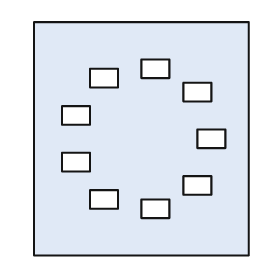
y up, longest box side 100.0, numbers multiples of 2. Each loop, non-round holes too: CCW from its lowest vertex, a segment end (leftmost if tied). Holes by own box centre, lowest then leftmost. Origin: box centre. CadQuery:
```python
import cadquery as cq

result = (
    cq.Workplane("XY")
    .moveTo(-46.0, -50.0)
    .lineTo(46.0, -50.0)
    .lineTo(46.0, 50.0)
    .lineTo(-46.0, 50.0)
    .close()
    .moveTo(0.0, -34.0)
    .lineTo(12.0, -34.0)
    .lineTo(12.0, -26.0)
    .lineTo(0.0, -26.0)
    .close()
    .moveTo(-22.0, -30.0)
    .lineTo(-10.0, -30.0)
    .lineTo(-10.0, -22.0)
    .lineTo(-22.0, -22.0)
    .close()
    .moveTo(18.0, -24.0)
    .lineTo(30.0, -24.0)
    .lineTo(30.0, -16.0)
    .lineTo(18.0, -16.0)
    .close()
    .moveTo(-34.0, -14.0)
    .lineTo(-22.0, -14.0)
    .lineTo(-22.0, -6.0)
    .lineTo(-34.0, -6.0)
    .close()
    .moveTo(24.0, -4.0)
    .lineTo(36.0, -4.0)
    .lineTo(36.0, 4.0)
    .lineTo(24.0, 4.0)
    .close()
    .moveTo(-34.0, 6.0)
    .lineTo(-22.0, 6.0)
    .lineTo(-22.0, 14.0)
    .lineTo(-34.0, 14.0)
    .close()
    .moveTo(18.0, 16.0)
    .lineTo(30.0, 16.0)
    .lineTo(30.0, 24.0)
    .lineTo(18.0, 24.0)
    .close()
    .moveTo(-22.0, 22.0)
    .lineTo(-10.0, 22.0)
    .lineTo(-10.0, 30.0)
    .lineTo(-22.0, 30.0)
    .close()
    .moveTo(0.0, 26.0)
    .lineTo(12.0, 26.0)
    .lineTo(12.0, 34.0)
    .lineTo(0.0, 34.0)
    .close()
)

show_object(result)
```